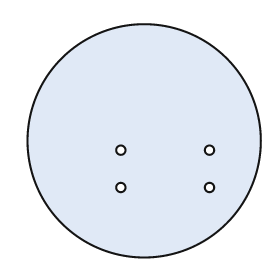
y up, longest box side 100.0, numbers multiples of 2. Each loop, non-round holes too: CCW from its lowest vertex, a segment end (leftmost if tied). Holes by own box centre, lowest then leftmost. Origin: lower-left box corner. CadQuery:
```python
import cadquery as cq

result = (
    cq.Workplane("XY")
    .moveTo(50.0, 50.0)
    .circle(50.0)
    .moveTo(40.0, 30.0)
    .circle(2.0)
    .moveTo(78.0, 30.0)
    .circle(2.0)
    .moveTo(40.0, 46.0)
    .circle(2.0)
    .moveTo(78.0, 46.0)
    .circle(2.0)
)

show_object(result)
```